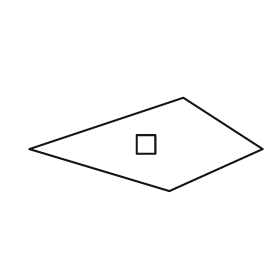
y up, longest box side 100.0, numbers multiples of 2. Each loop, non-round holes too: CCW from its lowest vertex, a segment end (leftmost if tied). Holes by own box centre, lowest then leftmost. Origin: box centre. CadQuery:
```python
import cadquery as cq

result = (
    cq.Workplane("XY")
    .moveTo(10.0, -20.0)
    .lineTo(50.0, -2.0)
    .lineTo(16.0, 20.0)
    .lineTo(-50.0, -2.0)
    .close()
    .moveTo(-4.0, -4.0)
    .lineTo(4.0, -4.0)
    .lineTo(4.0, 4.0)
    .lineTo(-4.0, 4.0)
    .close()
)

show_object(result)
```